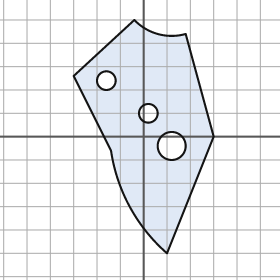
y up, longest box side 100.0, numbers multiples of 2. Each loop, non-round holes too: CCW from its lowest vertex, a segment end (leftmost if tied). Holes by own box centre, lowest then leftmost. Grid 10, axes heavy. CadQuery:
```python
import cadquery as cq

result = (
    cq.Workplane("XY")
    .moveTo(10.0, -50.0)
    .lineTo(30.0, 0.0)
    .lineTo(18.0, 44.0)
    .threePointArc((6.0, 44.0), (-4.0, 50.0))
    .lineTo(-30.0, 26.0)
    .lineTo(-14.0, -6.0)
    .threePointArc((-6.0, -30.0), (10.0, -50.0))
    .close()
    .moveTo(12.0, -4.0)
    .circle(6.0)
    .moveTo(2.0, 10.0)
    .circle(4.0)
    .moveTo(-16.0, 24.0)
    .circle(4.0)
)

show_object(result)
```